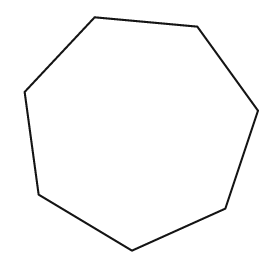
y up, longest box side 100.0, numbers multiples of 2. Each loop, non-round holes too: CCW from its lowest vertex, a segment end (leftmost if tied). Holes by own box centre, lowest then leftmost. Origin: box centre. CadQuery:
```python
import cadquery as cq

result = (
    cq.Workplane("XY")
    .moveTo(-4.0, -50.0)
    .lineTo(36.0, -32.0)
    .lineTo(50.0, 10.0)
    .lineTo(24.0, 46.0)
    .lineTo(-20.0, 50.0)
    .lineTo(-50.0, 18.0)
    .lineTo(-44.0, -26.0)
    .close()
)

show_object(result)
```